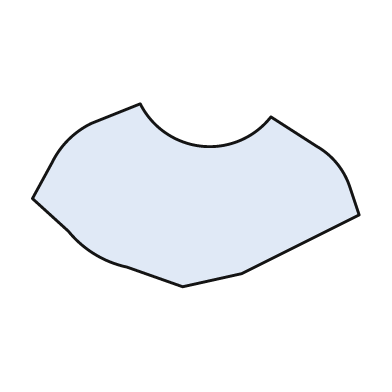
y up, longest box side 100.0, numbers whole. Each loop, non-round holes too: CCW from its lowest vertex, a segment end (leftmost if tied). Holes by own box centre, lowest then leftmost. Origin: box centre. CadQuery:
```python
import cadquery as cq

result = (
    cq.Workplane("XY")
    .moveTo(-4.0, -28.0)
    .lineTo(14.0, -24.0)
    .lineTo(50.0, -6.0)
    .lineTo(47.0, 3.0)
    .threePointArc((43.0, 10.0), (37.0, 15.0))
    .lineTo(23.0, 24.0)
    .threePointArc((2.0, 15.0), (-17.0, 28.0))
    .lineTo(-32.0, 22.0)
    .threePointArc((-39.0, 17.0), (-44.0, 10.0))
    .lineTo(-50.0, -1.0)
    .lineTo(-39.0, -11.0)
    .threePointArc((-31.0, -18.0), (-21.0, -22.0))
    .close()
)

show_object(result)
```